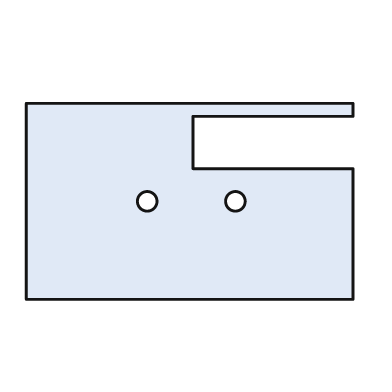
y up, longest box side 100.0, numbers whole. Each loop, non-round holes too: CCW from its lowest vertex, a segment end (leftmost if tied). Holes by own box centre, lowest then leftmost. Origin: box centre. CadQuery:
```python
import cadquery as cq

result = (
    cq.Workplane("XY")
    .moveTo(-50.0, -30.0)
    .lineTo(50.0, -30.0)
    .lineTo(50.0, 10.0)
    .lineTo(1.0, 10.0)
    .lineTo(1.0, 26.0)
    .lineTo(50.0, 26.0)
    .lineTo(50.0, 30.0)
    .lineTo(-50.0, 30.0)
    .close()
    .moveTo(-13.0, 0.0)
    .circle(3.0)
    .moveTo(14.0, 0.0)
    .circle(3.0)
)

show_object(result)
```